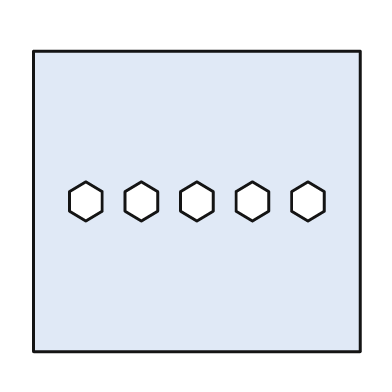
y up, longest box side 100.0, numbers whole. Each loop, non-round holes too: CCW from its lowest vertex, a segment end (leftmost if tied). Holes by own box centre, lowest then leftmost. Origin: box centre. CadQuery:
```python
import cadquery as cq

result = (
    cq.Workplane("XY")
    .moveTo(-50.0, -46.0)
    .lineTo(50.0, -46.0)
    .lineTo(50.0, 46.0)
    .lineTo(-50.0, 46.0)
    .close()
    .moveTo(-34.0, -6.0)
    .lineTo(-29.0, -3.0)
    .lineTo(-29.0, 3.0)
    .lineTo(-34.0, 6.0)
    .lineTo(-39.0, 3.0)
    .lineTo(-39.0, -3.0)
    .close()
    .moveTo(-17.0, -6.0)
    .lineTo(-12.0, -3.0)
    .lineTo(-12.0, 3.0)
    .lineTo(-17.0, 6.0)
    .lineTo(-22.0, 3.0)
    .lineTo(-22.0, -3.0)
    .close()
    .moveTo(0.0, -6.0)
    .lineTo(5.0, -3.0)
    .lineTo(5.0, 3.0)
    .lineTo(0.0, 6.0)
    .lineTo(-5.0, 3.0)
    .lineTo(-5.0, -3.0)
    .close()
    .moveTo(17.0, -6.0)
    .lineTo(22.0, -3.0)
    .lineTo(22.0, 3.0)
    .lineTo(17.0, 6.0)
    .lineTo(12.0, 3.0)
    .lineTo(12.0, -3.0)
    .close()
    .moveTo(34.0, -6.0)
    .lineTo(39.0, -3.0)
    .lineTo(39.0, 3.0)
    .lineTo(34.0, 6.0)
    .lineTo(29.0, 3.0)
    .lineTo(29.0, -3.0)
    .close()
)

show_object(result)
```